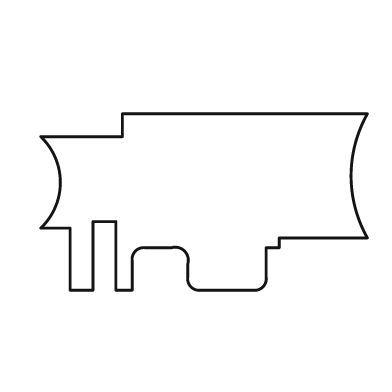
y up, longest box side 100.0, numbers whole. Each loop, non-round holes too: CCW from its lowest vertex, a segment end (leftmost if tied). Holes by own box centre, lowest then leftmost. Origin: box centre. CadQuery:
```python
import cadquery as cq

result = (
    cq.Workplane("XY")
    .moveTo(-41.0, -27.0)
    .lineTo(-34.0, -27.0)
    .lineTo(-34.0, -6.0)
    .lineTo(-27.0, -6.0)
    .lineTo(-27.0, -27.0)
    .lineTo(-22.0, -27.0)
    .lineTo(-22.0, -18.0)
    .threePointArc((-21.0, -15.0), (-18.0, -14.0))
    .lineTo(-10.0, -14.0)
    .threePointArc((-6.0, -15.0), (-5.0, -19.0))
    .lineTo(-5.0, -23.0)
    .threePointArc((-4.0, -26.0), (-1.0, -27.0))
    .lineTo(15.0, -27.0)
    .threePointArc((18.0, -26.0), (19.0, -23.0))
    .lineTo(19.0, -14.0)
    .lineTo(23.0, -14.0)
    .lineTo(23.0, -11.0)
    .lineTo(50.0, -11.0)
    .threePointArc((45.0, 8.0), (50.0, 27.0))
    .lineTo(-25.0, 27.0)
    .lineTo(-25.0, 20.0)
    .lineTo(-50.0, 20.0)
    .threePointArc((-44.0, 6.0), (-50.0, -8.0))
    .lineTo(-41.0, -8.0)
    .close()
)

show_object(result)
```